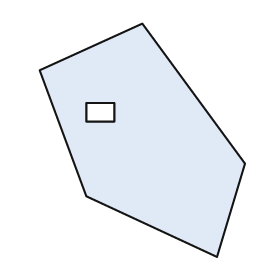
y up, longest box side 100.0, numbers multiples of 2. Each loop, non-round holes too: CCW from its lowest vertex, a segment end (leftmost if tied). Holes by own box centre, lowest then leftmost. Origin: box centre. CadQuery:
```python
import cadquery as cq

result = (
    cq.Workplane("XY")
    .moveTo(32.0, -50.0)
    .lineTo(44.0, -10.0)
    .lineTo(0.0, 50.0)
    .lineTo(-44.0, 30.0)
    .lineTo(-24.0, -24.0)
    .close()
    .moveTo(-24.0, 8.0)
    .lineTo(-12.0, 8.0)
    .lineTo(-12.0, 16.0)
    .lineTo(-24.0, 16.0)
    .close()
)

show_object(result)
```